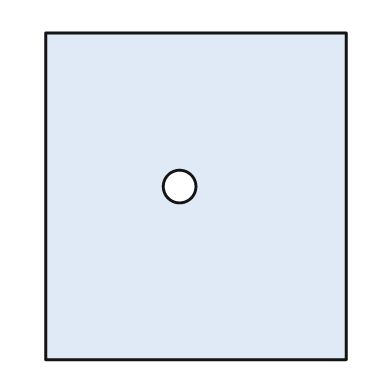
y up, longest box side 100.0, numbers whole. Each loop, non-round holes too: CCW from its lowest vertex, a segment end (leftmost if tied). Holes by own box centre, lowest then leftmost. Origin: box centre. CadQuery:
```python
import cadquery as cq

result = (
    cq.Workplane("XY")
    .moveTo(-46.0, -50.0)
    .lineTo(46.0, -50.0)
    .lineTo(46.0, 50.0)
    .lineTo(-46.0, 50.0)
    .close()
    .moveTo(-5.0, 3.0)
    .circle(5.0)
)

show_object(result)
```